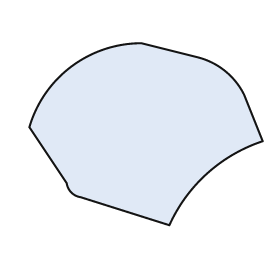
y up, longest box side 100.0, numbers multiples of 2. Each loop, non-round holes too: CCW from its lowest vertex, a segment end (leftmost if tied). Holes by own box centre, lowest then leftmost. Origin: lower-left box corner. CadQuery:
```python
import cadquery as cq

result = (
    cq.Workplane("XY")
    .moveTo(60.0, 0.0)
    .threePointArc((76.0, 22.0), (100.0, 36.0))
    .lineTo(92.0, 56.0)
    .threePointArc((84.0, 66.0), (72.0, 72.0))
    .lineTo(48.0, 78.0)
    .threePointArc((18.0, 68.0), (0.0, 42.0))
    .lineTo(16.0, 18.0)
    .threePointArc((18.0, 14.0), (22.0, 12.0))
    .close()
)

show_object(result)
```